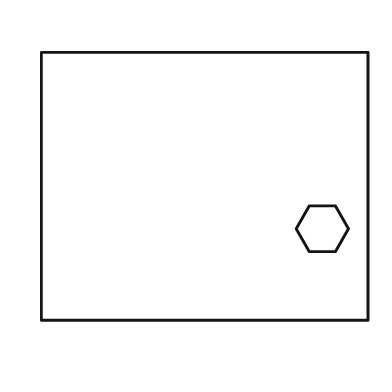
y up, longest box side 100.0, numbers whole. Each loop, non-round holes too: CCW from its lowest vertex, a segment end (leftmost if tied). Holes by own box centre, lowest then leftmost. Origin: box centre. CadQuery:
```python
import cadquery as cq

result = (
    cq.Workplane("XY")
    .moveTo(-50.0, -41.0)
    .lineTo(50.0, -41.0)
    .lineTo(50.0, 41.0)
    .lineTo(-50.0, 41.0)
    .close()
    .moveTo(32.0, -20.0)
    .lineTo(40.0, -20.0)
    .lineTo(44.0, -13.0)
    .lineTo(40.0, -6.0)
    .lineTo(32.0, -6.0)
    .lineTo(28.0, -13.0)
    .close()
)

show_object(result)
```